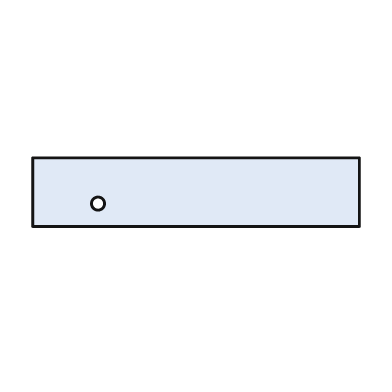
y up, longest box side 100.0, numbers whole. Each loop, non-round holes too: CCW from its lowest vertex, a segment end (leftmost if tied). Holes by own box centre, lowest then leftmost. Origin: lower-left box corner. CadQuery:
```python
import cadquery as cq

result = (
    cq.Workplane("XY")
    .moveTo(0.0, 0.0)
    .lineTo(100.0, 0.0)
    .lineTo(100.0, 21.0)
    .lineTo(0.0, 21.0)
    .close()
    .moveTo(20.0, 7.0)
    .circle(2.0)
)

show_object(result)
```